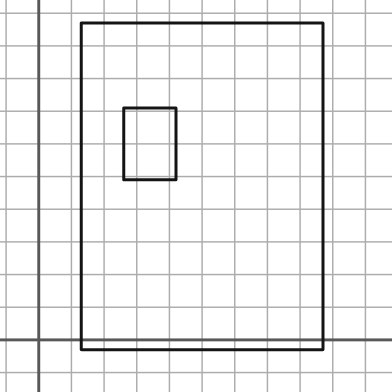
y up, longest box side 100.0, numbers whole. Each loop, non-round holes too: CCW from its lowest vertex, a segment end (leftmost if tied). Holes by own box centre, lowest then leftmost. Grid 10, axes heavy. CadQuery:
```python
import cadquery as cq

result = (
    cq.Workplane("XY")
    .moveTo(13.0, -3.0)
    .lineTo(87.0, -3.0)
    .lineTo(87.0, 97.0)
    .lineTo(13.0, 97.0)
    .close()
    .moveTo(26.0, 49.0)
    .lineTo(42.0, 49.0)
    .lineTo(42.0, 71.0)
    .lineTo(26.0, 71.0)
    .close()
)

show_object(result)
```